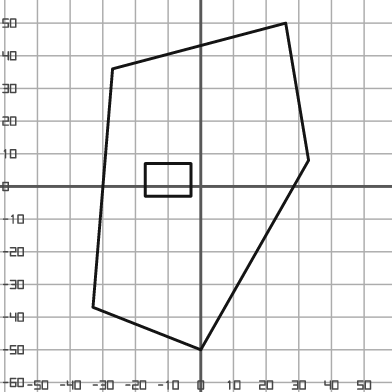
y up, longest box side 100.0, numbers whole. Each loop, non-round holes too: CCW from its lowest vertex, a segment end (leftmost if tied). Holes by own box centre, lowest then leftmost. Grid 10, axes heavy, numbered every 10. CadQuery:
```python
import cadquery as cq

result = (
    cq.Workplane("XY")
    .moveTo(0.0, -50.0)
    .lineTo(33.0, 8.0)
    .lineTo(26.0, 50.0)
    .lineTo(-27.0, 36.0)
    .lineTo(-33.0, -37.0)
    .close()
    .moveTo(-17.0, -3.0)
    .lineTo(-3.0, -3.0)
    .lineTo(-3.0, 7.0)
    .lineTo(-17.0, 7.0)
    .close()
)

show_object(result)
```